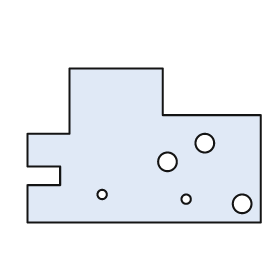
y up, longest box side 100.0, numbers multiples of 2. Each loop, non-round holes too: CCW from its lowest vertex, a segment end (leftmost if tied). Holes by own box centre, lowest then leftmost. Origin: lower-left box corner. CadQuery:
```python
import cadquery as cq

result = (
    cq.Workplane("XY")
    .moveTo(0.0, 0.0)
    .lineTo(100.0, 0.0)
    .lineTo(100.0, 46.0)
    .lineTo(58.0, 46.0)
    .lineTo(58.0, 66.0)
    .lineTo(18.0, 66.0)
    .lineTo(18.0, 38.0)
    .lineTo(0.0, 38.0)
    .lineTo(0.0, 24.0)
    .lineTo(14.0, 24.0)
    .lineTo(14.0, 16.0)
    .lineTo(0.0, 16.0)
    .close()
    .moveTo(92.0, 8.0)
    .circle(4.0)
    .moveTo(68.0, 10.0)
    .circle(2.0)
    .moveTo(32.0, 12.0)
    .circle(2.0)
    .moveTo(60.0, 26.0)
    .circle(4.0)
    .moveTo(76.0, 34.0)
    .circle(4.0)
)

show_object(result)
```